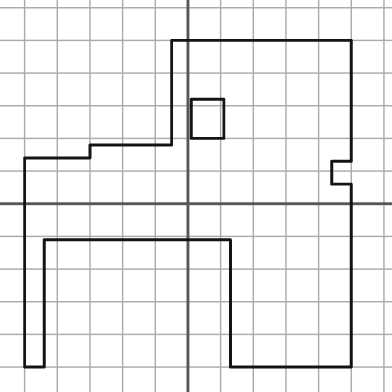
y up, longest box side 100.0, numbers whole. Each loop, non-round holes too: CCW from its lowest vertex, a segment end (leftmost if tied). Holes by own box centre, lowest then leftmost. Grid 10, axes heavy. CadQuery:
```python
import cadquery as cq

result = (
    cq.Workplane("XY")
    .moveTo(-50.0, -50.0)
    .lineTo(-44.0, -50.0)
    .lineTo(-44.0, -11.0)
    .lineTo(13.0, -11.0)
    .lineTo(13.0, -50.0)
    .lineTo(50.0, -50.0)
    .lineTo(50.0, 6.0)
    .lineTo(44.0, 6.0)
    .lineTo(44.0, 13.0)
    .lineTo(50.0, 13.0)
    .lineTo(50.0, 50.0)
    .lineTo(-5.0, 50.0)
    .lineTo(-5.0, 18.0)
    .lineTo(-30.0, 18.0)
    .lineTo(-30.0, 14.0)
    .lineTo(-50.0, 14.0)
    .close()
    .moveTo(1.0, 20.0)
    .lineTo(11.0, 20.0)
    .lineTo(11.0, 32.0)
    .lineTo(1.0, 32.0)
    .close()
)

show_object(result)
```